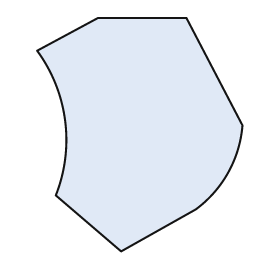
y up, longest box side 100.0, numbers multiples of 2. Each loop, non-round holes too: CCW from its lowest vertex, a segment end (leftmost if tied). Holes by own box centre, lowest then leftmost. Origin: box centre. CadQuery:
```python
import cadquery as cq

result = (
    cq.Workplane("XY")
    .moveTo(-8.0, -50.0)
    .lineTo(24.0, -32.0)
    .threePointArc((38.0, -16.0), (44.0, 4.0))
    .lineTo(20.0, 50.0)
    .lineTo(-18.0, 50.0)
    .lineTo(-44.0, 36.0)
    .threePointArc((-32.0, 6.0), (-36.0, -26.0))
    .close()
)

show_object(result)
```